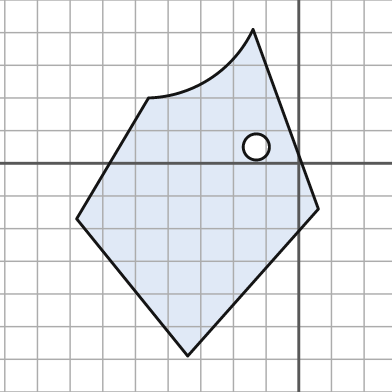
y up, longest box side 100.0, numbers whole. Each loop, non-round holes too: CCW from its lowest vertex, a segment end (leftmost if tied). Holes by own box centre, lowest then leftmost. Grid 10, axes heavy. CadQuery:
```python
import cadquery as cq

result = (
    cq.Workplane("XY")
    .moveTo(-34.0, -59.0)
    .lineTo(6.0, -14.0)
    .lineTo(-14.0, 41.0)
    .threePointArc((-27.0, 26.0), (-46.0, 20.0))
    .lineTo(-68.0, -17.0)
    .close()
    .moveTo(-13.0, 5.0)
    .circle(4.0)
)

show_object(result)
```